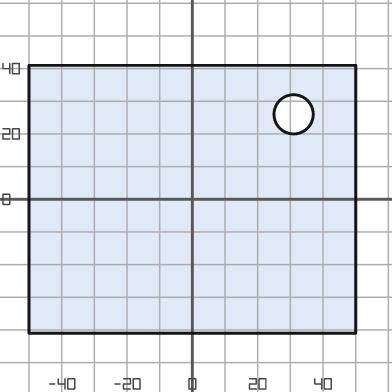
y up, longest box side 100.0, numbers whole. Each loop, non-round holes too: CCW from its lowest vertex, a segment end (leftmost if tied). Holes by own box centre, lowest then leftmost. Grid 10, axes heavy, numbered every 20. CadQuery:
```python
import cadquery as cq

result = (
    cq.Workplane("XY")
    .moveTo(-50.0, -41.0)
    .lineTo(50.0, -41.0)
    .lineTo(50.0, 41.0)
    .lineTo(-50.0, 41.0)
    .close()
    .moveTo(31.0, 26.0)
    .circle(6.0)
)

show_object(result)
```